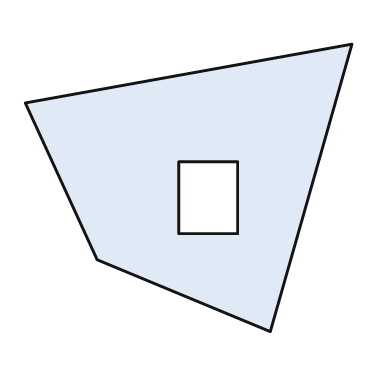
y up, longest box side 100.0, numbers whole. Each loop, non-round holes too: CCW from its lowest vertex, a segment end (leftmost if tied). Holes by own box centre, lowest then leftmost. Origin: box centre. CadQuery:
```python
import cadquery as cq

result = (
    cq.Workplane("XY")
    .moveTo(25.0, -44.0)
    .lineTo(50.0, 44.0)
    .lineTo(-50.0, 26.0)
    .lineTo(-28.0, -22.0)
    .close()
    .moveTo(-3.0, -14.0)
    .lineTo(15.0, -14.0)
    .lineTo(15.0, 8.0)
    .lineTo(-3.0, 8.0)
    .close()
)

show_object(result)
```